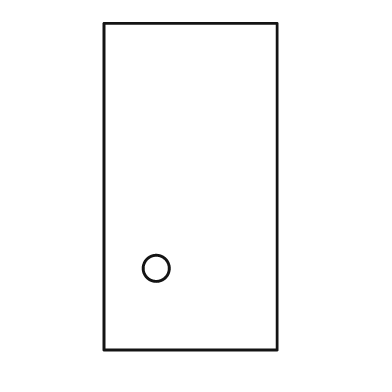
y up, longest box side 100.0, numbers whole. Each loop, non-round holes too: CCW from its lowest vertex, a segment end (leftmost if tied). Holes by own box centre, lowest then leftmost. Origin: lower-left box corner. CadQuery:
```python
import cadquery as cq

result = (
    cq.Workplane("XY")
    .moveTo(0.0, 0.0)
    .lineTo(53.0, 0.0)
    .lineTo(53.0, 100.0)
    .lineTo(0.0, 100.0)
    .close()
    .moveTo(16.0, 25.0)
    .circle(4.0)
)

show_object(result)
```